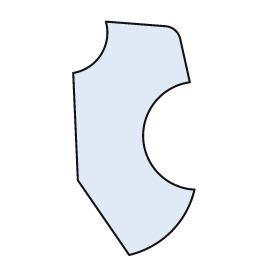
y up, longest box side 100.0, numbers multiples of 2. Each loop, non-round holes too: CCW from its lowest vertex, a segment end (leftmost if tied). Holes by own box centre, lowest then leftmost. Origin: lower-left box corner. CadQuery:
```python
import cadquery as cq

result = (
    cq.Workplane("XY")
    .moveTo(24.0, 0.0)
    .threePointArc((42.0, 10.0), (52.0, 28.0))
    .threePointArc((30.0, 50.0), (50.0, 74.0))
    .lineTo(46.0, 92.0)
    .threePointArc((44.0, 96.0), (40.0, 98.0))
    .lineTo(14.0, 100.0)
    .threePointArc((12.0, 86.0), (0.0, 78.0))
    .lineTo(2.0, 32.0)
    .close()
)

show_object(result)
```